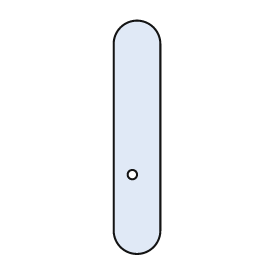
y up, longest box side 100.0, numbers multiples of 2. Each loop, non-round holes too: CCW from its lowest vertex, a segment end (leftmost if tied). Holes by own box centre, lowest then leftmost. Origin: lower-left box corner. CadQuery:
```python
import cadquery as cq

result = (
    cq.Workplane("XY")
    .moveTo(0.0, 10.0)
    .threePointArc((10.0, 0.0), (20.0, 10.0))
    .lineTo(20.0, 90.0)
    .threePointArc((10.0, 100.0), (0.0, 90.0))
    .close()
    .moveTo(8.0, 34.0)
    .circle(2.0)
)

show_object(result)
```